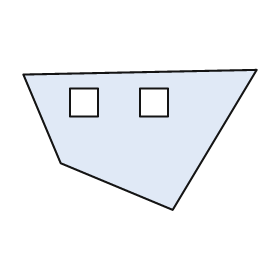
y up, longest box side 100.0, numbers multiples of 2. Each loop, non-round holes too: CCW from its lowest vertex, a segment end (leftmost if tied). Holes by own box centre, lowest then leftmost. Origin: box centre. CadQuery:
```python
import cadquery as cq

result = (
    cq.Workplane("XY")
    .moveTo(14.0, -30.0)
    .lineTo(50.0, 30.0)
    .lineTo(-50.0, 28.0)
    .lineTo(-34.0, -10.0)
    .close()
    .moveTo(-30.0, 10.0)
    .lineTo(-18.0, 10.0)
    .lineTo(-18.0, 22.0)
    .lineTo(-30.0, 22.0)
    .close()
    .moveTo(0.0, 10.0)
    .lineTo(12.0, 10.0)
    .lineTo(12.0, 22.0)
    .lineTo(0.0, 22.0)
    .close()
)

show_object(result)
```